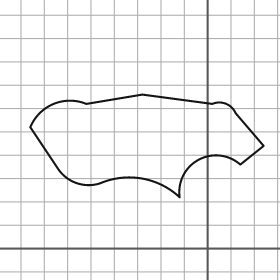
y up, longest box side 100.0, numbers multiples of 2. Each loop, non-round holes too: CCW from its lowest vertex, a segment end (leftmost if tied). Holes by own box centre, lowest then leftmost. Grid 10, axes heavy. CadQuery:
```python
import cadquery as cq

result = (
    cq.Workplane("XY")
    .moveTo(-12.0, 22.0)
    .threePointArc((-4.0, 38.0), (14.0, 36.0))
    .lineTo(24.0, 44.0)
    .lineTo(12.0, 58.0)
    .threePointArc((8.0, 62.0), (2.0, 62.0))
    .lineTo(-28.0, 66.0)
    .lineTo(-52.0, 62.0)
    .threePointArc((-66.0, 62.0), (-76.0, 52.0))
    .lineTo(-64.0, 34.0)
    .threePointArc((-56.0, 28.0), (-46.0, 28.0))
    .threePointArc((-28.0, 30.0), (-12.0, 22.0))
    .close()
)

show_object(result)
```